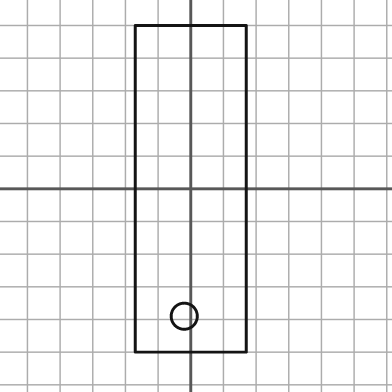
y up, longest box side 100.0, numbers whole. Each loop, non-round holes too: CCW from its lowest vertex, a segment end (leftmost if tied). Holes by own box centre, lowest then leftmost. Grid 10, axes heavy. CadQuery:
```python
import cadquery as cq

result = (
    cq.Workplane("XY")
    .moveTo(-17.0, -50.0)
    .lineTo(17.0, -50.0)
    .lineTo(17.0, 50.0)
    .lineTo(-17.0, 50.0)
    .close()
    .moveTo(-2.0, -39.0)
    .circle(4.0)
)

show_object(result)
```